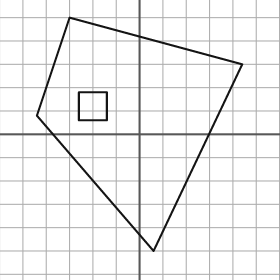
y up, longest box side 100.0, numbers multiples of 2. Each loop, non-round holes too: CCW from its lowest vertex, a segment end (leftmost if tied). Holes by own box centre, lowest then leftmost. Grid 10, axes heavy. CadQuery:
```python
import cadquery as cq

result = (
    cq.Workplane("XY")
    .moveTo(6.0, -50.0)
    .lineTo(44.0, 30.0)
    .lineTo(-30.0, 50.0)
    .lineTo(-44.0, 8.0)
    .close()
    .moveTo(-26.0, 6.0)
    .lineTo(-14.0, 6.0)
    .lineTo(-14.0, 18.0)
    .lineTo(-26.0, 18.0)
    .close()
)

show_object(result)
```